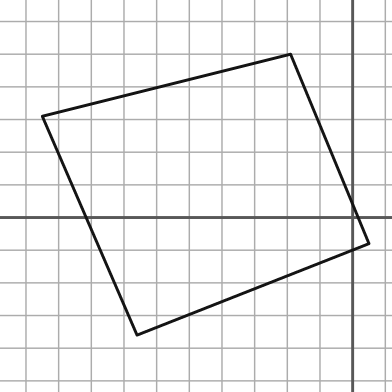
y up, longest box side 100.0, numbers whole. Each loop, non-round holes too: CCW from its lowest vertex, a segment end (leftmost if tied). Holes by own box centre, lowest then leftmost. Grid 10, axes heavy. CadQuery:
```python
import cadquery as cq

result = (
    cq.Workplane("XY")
    .moveTo(-66.0, -36.0)
    .lineTo(5.0, -8.0)
    .lineTo(-19.0, 50.0)
    .lineTo(-95.0, 31.0)
    .close()
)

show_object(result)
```